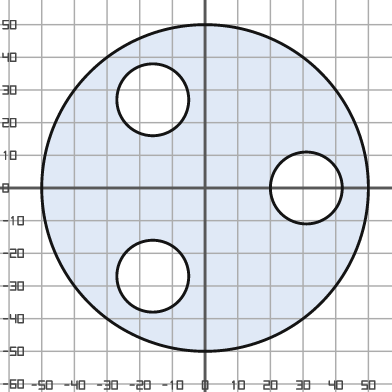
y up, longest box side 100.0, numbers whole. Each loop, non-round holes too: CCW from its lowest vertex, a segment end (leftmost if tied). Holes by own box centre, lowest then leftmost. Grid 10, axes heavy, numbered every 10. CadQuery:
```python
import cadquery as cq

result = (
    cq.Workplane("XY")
    .moveTo(0.0, 0.0)
    .circle(50.0)
    .moveTo(-16.0, -27.0)
    .circle(11.0)
    .moveTo(31.0, 0.0)
    .circle(11.0)
    .moveTo(-16.0, 27.0)
    .circle(11.0)
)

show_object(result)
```